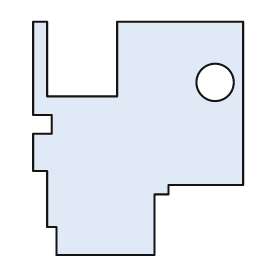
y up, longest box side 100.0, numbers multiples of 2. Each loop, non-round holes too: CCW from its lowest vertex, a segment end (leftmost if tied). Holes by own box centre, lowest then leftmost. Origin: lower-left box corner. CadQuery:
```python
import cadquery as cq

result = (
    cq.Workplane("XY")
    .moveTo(10.0, 0.0)
    .lineTo(52.0, 0.0)
    .lineTo(52.0, 26.0)
    .lineTo(58.0, 26.0)
    .lineTo(58.0, 30.0)
    .lineTo(90.0, 30.0)
    .lineTo(90.0, 100.0)
    .lineTo(36.0, 100.0)
    .lineTo(36.0, 68.0)
    .lineTo(6.0, 68.0)
    .lineTo(6.0, 100.0)
    .lineTo(0.0, 100.0)
    .lineTo(0.0, 60.0)
    .lineTo(8.0, 60.0)
    .lineTo(8.0, 52.0)
    .lineTo(0.0, 52.0)
    .lineTo(0.0, 36.0)
    .lineTo(6.0, 36.0)
    .lineTo(6.0, 12.0)
    .lineTo(10.0, 12.0)
    .close()
    .moveTo(78.0, 74.0)
    .circle(8.0)
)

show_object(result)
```